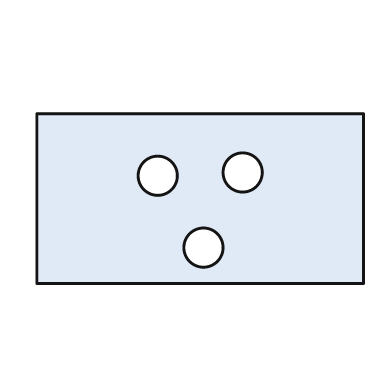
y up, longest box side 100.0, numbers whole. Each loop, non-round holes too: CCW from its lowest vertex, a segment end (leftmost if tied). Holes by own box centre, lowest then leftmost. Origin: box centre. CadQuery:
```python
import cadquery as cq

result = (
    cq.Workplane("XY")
    .moveTo(-50.0, -26.0)
    .lineTo(50.0, -26.0)
    .lineTo(50.0, 26.0)
    .lineTo(-50.0, 26.0)
    .close()
    .moveTo(1.0, -15.0)
    .circle(6.0)
    .moveTo(-13.0, 7.0)
    .circle(6.0)
    .moveTo(13.0, 8.0)
    .circle(6.0)
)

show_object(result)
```